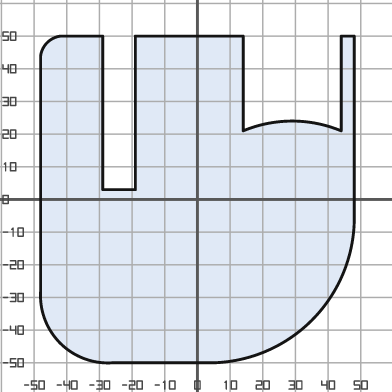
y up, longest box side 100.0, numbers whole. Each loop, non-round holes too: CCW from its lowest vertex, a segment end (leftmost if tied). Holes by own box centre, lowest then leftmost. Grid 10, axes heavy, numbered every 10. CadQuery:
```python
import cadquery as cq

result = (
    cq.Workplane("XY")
    .moveTo(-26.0, -50.0)
    .lineTo(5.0, -50.0)
    .threePointArc((35.0, -37.0), (48.0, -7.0))
    .lineTo(48.0, 50.0)
    .lineTo(44.0, 50.0)
    .lineTo(44.0, 21.0)
    .threePointArc((29.0, 24.0), (14.0, 21.0))
    .lineTo(14.0, 50.0)
    .lineTo(-19.0, 50.0)
    .lineTo(-19.0, 3.0)
    .lineTo(-29.0, 3.0)
    .lineTo(-29.0, 50.0)
    .lineTo(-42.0, 50.0)
    .threePointArc((-46.0, 48.0), (-48.0, 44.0))
    .lineTo(-48.0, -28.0)
    .threePointArc((-42.0, -44.0), (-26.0, -50.0))
    .close()
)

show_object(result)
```